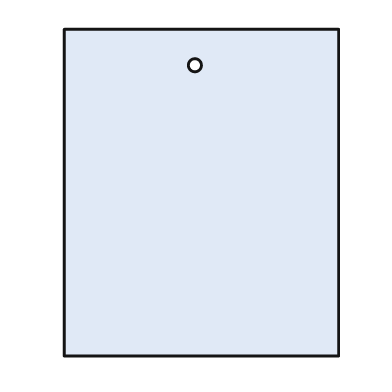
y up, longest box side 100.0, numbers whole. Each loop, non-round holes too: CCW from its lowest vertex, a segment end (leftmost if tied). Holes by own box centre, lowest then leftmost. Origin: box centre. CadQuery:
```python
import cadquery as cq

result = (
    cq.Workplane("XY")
    .moveTo(-42.0, -50.0)
    .lineTo(42.0, -50.0)
    .lineTo(42.0, 50.0)
    .lineTo(-42.0, 50.0)
    .close()
    .moveTo(-2.0, 39.0)
    .circle(2.0)
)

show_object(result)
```